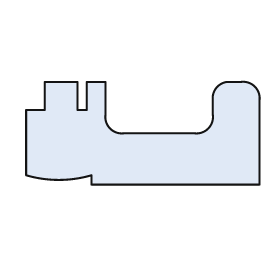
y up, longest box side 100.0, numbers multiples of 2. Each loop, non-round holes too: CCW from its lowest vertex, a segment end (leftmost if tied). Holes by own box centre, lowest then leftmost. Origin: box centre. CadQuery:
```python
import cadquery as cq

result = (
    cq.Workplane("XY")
    .moveTo(-22.0, -22.0)
    .lineTo(50.0, -22.0)
    .lineTo(50.0, 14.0)
    .threePointArc((48.0, 20.0), (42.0, 22.0))
    .lineTo(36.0, 22.0)
    .threePointArc((32.0, 20.0), (30.0, 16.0))
    .lineTo(30.0, 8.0)
    .threePointArc((28.0, 2.0), (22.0, 0.0))
    .lineTo(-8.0, 0.0)
    .threePointArc((-14.0, 2.0), (-16.0, 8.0))
    .lineTo(-16.0, 22.0)
    .lineTo(-24.0, 22.0)
    .lineTo(-24.0, 10.0)
    .lineTo(-28.0, 10.0)
    .lineTo(-28.0, 22.0)
    .lineTo(-42.0, 22.0)
    .lineTo(-42.0, 10.0)
    .lineTo(-50.0, 10.0)
    .lineTo(-50.0, -18.0)
    .threePointArc((-36.0, -20.0), (-22.0, -18.0))
    .close()
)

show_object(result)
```